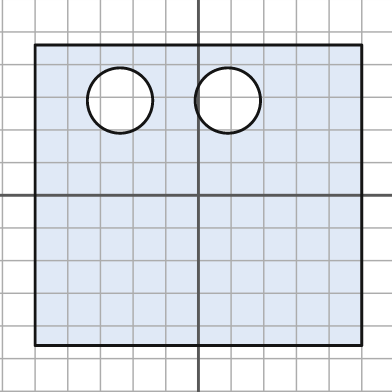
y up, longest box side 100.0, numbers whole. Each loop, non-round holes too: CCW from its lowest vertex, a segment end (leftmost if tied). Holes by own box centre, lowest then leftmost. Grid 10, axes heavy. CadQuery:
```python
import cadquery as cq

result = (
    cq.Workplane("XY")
    .moveTo(-50.0, -46.0)
    .lineTo(50.0, -46.0)
    .lineTo(50.0, 46.0)
    .lineTo(-50.0, 46.0)
    .close()
    .moveTo(-24.0, 29.0)
    .circle(10.0)
    .moveTo(9.0, 29.0)
    .circle(10.0)
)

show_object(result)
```